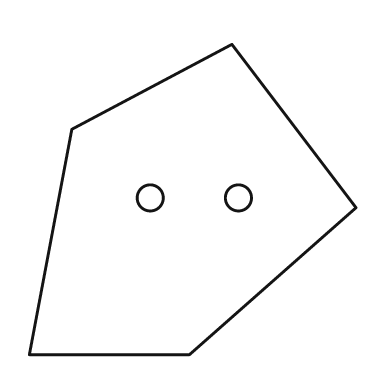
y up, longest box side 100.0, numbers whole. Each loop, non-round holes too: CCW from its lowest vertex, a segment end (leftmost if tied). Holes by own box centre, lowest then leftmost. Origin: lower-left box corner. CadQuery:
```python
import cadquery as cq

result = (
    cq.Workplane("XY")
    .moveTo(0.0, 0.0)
    .lineTo(49.0, 0.0)
    .lineTo(100.0, 45.0)
    .lineTo(62.0, 95.0)
    .lineTo(13.0, 69.0)
    .close()
    .moveTo(37.0, 48.0)
    .circle(4.0)
    .moveTo(64.0, 48.0)
    .circle(4.0)
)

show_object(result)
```